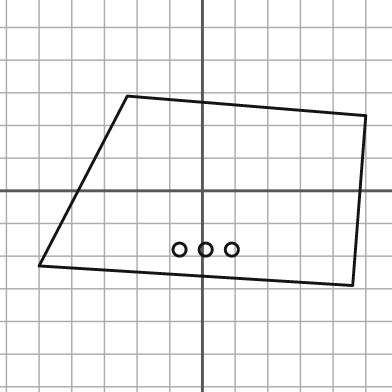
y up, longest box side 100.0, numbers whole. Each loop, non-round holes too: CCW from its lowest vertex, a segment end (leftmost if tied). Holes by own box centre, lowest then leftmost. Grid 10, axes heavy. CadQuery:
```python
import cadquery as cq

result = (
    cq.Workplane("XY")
    .moveTo(46.0, -29.0)
    .lineTo(50.0, 23.0)
    .lineTo(-23.0, 29.0)
    .lineTo(-50.0, -23.0)
    .close()
    .moveTo(-7.0, -18.0)
    .circle(2.0)
    .moveTo(1.0, -18.0)
    .circle(2.0)
    .moveTo(9.0, -18.0)
    .circle(2.0)
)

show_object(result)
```